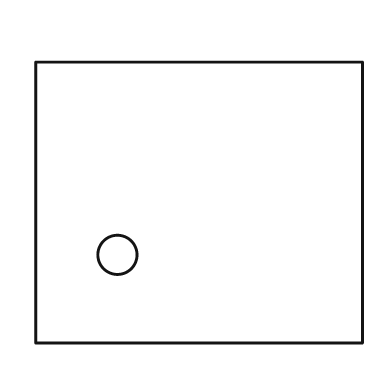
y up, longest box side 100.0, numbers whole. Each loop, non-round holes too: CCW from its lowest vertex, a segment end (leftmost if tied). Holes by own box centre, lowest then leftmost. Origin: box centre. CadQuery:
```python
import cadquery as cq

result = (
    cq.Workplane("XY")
    .moveTo(-50.0, -43.0)
    .lineTo(50.0, -43.0)
    .lineTo(50.0, 43.0)
    .lineTo(-50.0, 43.0)
    .close()
    .moveTo(-25.0, -16.0)
    .circle(6.0)
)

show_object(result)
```